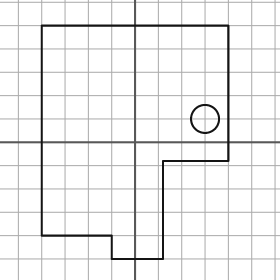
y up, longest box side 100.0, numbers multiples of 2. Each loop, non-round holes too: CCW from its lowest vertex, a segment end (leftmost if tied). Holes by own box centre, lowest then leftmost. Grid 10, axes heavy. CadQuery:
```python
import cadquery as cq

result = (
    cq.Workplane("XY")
    .moveTo(-10.0, -50.0)
    .lineTo(12.0, -50.0)
    .lineTo(12.0, -8.0)
    .lineTo(40.0, -8.0)
    .lineTo(40.0, 50.0)
    .lineTo(-40.0, 50.0)
    .lineTo(-40.0, -40.0)
    .lineTo(-10.0, -40.0)
    .close()
    .moveTo(30.0, 10.0)
    .circle(6.0)
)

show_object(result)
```